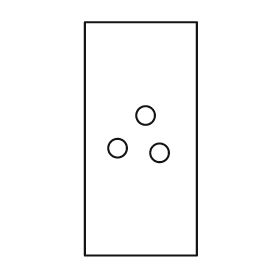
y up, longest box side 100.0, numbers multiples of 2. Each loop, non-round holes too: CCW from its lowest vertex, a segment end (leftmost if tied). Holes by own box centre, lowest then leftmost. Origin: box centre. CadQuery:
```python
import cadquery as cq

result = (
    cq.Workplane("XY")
    .moveTo(-24.0, -50.0)
    .lineTo(24.0, -50.0)
    .lineTo(24.0, 50.0)
    .lineTo(-24.0, 50.0)
    .close()
    .moveTo(8.0, -6.0)
    .circle(4.0)
    .moveTo(-10.0, -4.0)
    .circle(4.0)
    .moveTo(2.0, 10.0)
    .circle(4.0)
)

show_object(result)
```